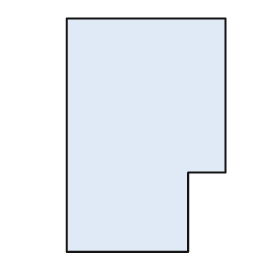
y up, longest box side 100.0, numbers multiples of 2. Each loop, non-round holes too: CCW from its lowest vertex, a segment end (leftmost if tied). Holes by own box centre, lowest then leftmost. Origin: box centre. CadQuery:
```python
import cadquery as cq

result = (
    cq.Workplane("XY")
    .moveTo(-34.0, -50.0)
    .lineTo(18.0, -50.0)
    .lineTo(18.0, -16.0)
    .lineTo(34.0, -16.0)
    .lineTo(34.0, 50.0)
    .lineTo(-34.0, 50.0)
    .close()
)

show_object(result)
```